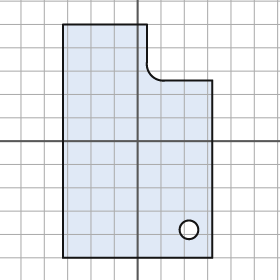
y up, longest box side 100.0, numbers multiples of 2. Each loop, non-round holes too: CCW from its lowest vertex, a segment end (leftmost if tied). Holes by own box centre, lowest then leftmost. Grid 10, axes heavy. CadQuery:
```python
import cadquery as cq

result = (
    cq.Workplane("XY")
    .moveTo(-32.0, -50.0)
    .lineTo(32.0, -50.0)
    .lineTo(32.0, 26.0)
    .lineTo(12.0, 26.0)
    .threePointArc((6.0, 28.0), (4.0, 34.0))
    .lineTo(4.0, 50.0)
    .lineTo(-32.0, 50.0)
    .close()
    .moveTo(22.0, -38.0)
    .circle(4.0)
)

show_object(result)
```